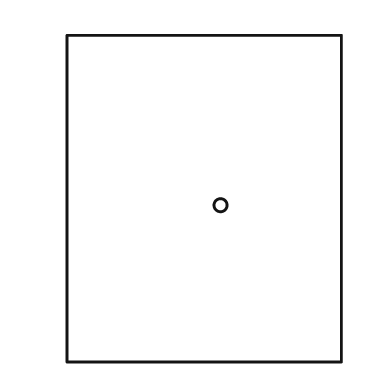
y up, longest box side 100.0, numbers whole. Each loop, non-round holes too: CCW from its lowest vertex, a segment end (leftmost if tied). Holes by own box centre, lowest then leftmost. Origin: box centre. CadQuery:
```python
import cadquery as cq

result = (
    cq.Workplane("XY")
    .moveTo(-42.0, -50.0)
    .lineTo(42.0, -50.0)
    .lineTo(42.0, 50.0)
    .lineTo(-42.0, 50.0)
    .close()
    .moveTo(5.0, -2.0)
    .circle(2.0)
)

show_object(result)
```